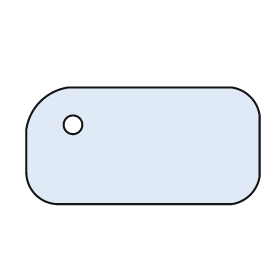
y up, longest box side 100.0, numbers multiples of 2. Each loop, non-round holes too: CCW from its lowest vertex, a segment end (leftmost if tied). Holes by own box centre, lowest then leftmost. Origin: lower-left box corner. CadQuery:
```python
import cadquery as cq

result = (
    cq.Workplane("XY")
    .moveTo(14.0, 0.0)
    .lineTo(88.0, 0.0)
    .threePointArc((96.0, 4.0), (100.0, 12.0))
    .lineTo(100.0, 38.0)
    .threePointArc((96.0, 46.0), (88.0, 50.0))
    .lineTo(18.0, 50.0)
    .threePointArc((6.0, 44.0), (0.0, 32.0))
    .lineTo(0.0, 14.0)
    .threePointArc((4.0, 4.0), (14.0, 0.0))
    .close()
    .moveTo(20.0, 34.0)
    .circle(4.0)
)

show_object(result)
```